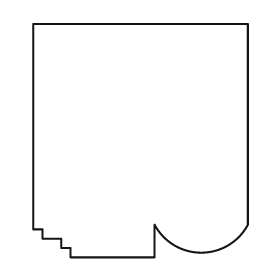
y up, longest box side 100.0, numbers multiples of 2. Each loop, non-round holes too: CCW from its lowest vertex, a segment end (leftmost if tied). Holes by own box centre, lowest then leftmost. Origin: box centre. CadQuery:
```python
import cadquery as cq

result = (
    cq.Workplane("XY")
    .moveTo(-30.0, -50.0)
    .lineTo(6.0, -50.0)
    .lineTo(6.0, -36.0)
    .threePointArc((26.0, -48.0), (46.0, -36.0))
    .lineTo(46.0, 50.0)
    .lineTo(-46.0, 50.0)
    .lineTo(-46.0, -38.0)
    .lineTo(-42.0, -38.0)
    .lineTo(-42.0, -42.0)
    .lineTo(-34.0, -42.0)
    .lineTo(-34.0, -46.0)
    .lineTo(-30.0, -46.0)
    .close()
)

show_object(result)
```